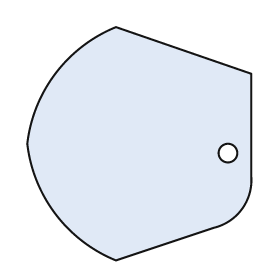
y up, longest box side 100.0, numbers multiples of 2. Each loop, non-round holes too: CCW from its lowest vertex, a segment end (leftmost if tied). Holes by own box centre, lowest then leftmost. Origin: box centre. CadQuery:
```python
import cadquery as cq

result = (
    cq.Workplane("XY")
    .moveTo(-10.0, -50.0)
    .lineTo(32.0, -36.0)
    .threePointArc((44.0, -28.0), (48.0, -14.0))
    .lineTo(48.0, 30.0)
    .lineTo(-10.0, 50.0)
    .threePointArc((-36.0, 30.0), (-48.0, 0.0))
    .threePointArc((-36.0, -30.0), (-10.0, -50.0))
    .close()
    .moveTo(38.0, -4.0)
    .circle(4.0)
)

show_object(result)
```